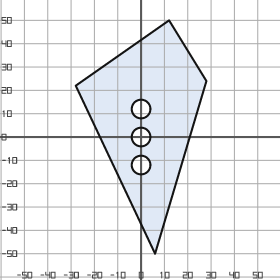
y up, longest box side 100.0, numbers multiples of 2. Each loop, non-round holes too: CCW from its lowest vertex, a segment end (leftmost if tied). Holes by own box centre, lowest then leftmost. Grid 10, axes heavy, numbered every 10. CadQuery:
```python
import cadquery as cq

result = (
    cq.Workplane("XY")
    .moveTo(6.0, -50.0)
    .lineTo(28.0, 24.0)
    .lineTo(12.0, 50.0)
    .lineTo(-28.0, 22.0)
    .close()
    .moveTo(0.0, -12.0)
    .circle(4.0)
    .moveTo(0.0, 0.0)
    .circle(4.0)
    .moveTo(0.0, 12.0)
    .circle(4.0)
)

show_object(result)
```